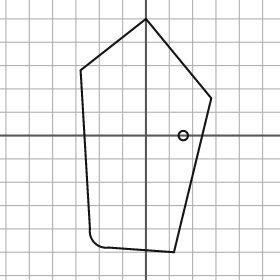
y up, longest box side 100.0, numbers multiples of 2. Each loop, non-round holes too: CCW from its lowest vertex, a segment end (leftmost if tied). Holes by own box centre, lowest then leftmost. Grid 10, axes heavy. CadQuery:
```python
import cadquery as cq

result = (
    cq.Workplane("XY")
    .moveTo(12.0, -50.0)
    .lineTo(28.0, 16.0)
    .lineTo(0.0, 50.0)
    .lineTo(-28.0, 28.0)
    .lineTo(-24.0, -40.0)
    .threePointArc((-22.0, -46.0), (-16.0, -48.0))
    .close()
    .moveTo(16.0, 0.0)
    .circle(2.0)
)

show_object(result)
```